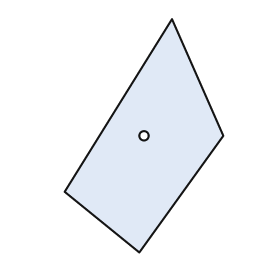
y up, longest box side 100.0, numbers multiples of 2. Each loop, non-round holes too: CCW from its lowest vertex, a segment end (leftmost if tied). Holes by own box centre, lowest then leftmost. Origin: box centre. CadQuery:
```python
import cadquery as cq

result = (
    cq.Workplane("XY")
    .moveTo(-2.0, -50.0)
    .lineTo(34.0, 0.0)
    .lineTo(12.0, 50.0)
    .lineTo(-34.0, -24.0)
    .close()
    .moveTo(0.0, 0.0)
    .circle(2.0)
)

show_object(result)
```